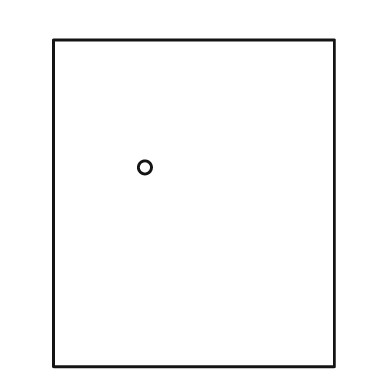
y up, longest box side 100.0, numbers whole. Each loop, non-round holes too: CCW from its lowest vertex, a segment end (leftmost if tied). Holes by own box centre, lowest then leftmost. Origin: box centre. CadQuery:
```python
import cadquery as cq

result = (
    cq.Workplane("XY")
    .moveTo(-43.0, -50.0)
    .lineTo(43.0, -50.0)
    .lineTo(43.0, 50.0)
    .lineTo(-43.0, 50.0)
    .close()
    .moveTo(-15.0, 11.0)
    .circle(2.0)
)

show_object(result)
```